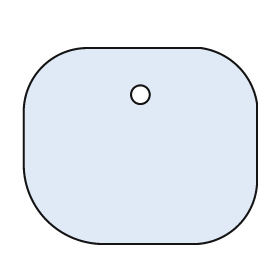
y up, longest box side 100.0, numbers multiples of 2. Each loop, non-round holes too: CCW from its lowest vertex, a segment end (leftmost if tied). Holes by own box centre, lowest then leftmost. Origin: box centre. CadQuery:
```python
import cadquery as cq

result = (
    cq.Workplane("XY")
    .moveTo(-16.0, -42.0)
    .lineTo(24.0, -42.0)
    .threePointArc((42.0, -34.0), (50.0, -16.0))
    .lineTo(50.0, 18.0)
    .threePointArc((42.0, 34.0), (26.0, 42.0))
    .lineTo(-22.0, 42.0)
    .threePointArc((-42.0, 34.0), (-50.0, 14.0))
    .lineTo(-50.0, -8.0)
    .threePointArc((-40.0, -32.0), (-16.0, -42.0))
    .close()
    .moveTo(0.0, 22.0)
    .circle(4.0)
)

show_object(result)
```